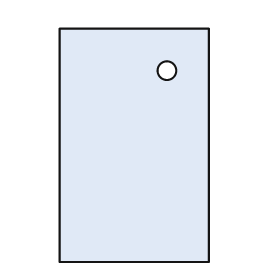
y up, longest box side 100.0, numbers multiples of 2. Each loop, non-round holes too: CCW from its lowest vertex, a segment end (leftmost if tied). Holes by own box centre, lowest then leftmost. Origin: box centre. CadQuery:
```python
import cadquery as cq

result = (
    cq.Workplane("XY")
    .moveTo(-32.0, -50.0)
    .lineTo(32.0, -50.0)
    .lineTo(32.0, 50.0)
    .lineTo(-32.0, 50.0)
    .close()
    .moveTo(14.0, 32.0)
    .circle(4.0)
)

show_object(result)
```